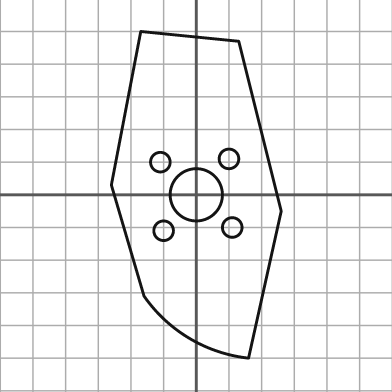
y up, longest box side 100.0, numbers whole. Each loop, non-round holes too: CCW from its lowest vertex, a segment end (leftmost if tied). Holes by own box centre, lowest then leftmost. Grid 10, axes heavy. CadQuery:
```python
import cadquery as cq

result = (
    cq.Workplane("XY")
    .moveTo(16.0, -50.0)
    .lineTo(26.0, -5.0)
    .lineTo(13.0, 47.0)
    .lineTo(-17.0, 50.0)
    .lineTo(-26.0, 3.0)
    .lineTo(-16.0, -31.0)
    .threePointArc((-2.0, -44.0), (16.0, -50.0))
    .close()
    .moveTo(-10.0, -11.0)
    .circle(3.0)
    .moveTo(11.0, -10.0)
    .circle(3.0)
    .moveTo(0.0, 0.0)
    .circle(8.0)
    .moveTo(-11.0, 10.0)
    .circle(3.0)
    .moveTo(10.0, 11.0)
    .circle(3.0)
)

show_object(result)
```